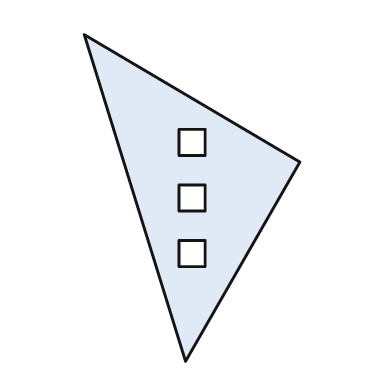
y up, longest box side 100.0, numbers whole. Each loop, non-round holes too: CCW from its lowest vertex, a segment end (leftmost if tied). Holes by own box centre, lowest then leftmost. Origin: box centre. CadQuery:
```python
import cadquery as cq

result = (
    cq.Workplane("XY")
    .moveTo(-2.0, -50.0)
    .lineTo(33.0, 11.0)
    .lineTo(-33.0, 50.0)
    .close()
    .moveTo(-4.0, -21.0)
    .lineTo(4.0, -21.0)
    .lineTo(4.0, -13.0)
    .lineTo(-4.0, -13.0)
    .close()
    .moveTo(-4.0, -4.0)
    .lineTo(4.0, -4.0)
    .lineTo(4.0, 4.0)
    .lineTo(-4.0, 4.0)
    .close()
    .moveTo(-4.0, 13.0)
    .lineTo(4.0, 13.0)
    .lineTo(4.0, 21.0)
    .lineTo(-4.0, 21.0)
    .close()
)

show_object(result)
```